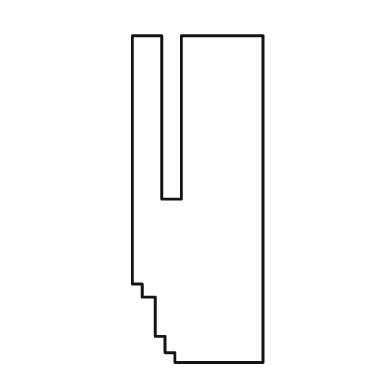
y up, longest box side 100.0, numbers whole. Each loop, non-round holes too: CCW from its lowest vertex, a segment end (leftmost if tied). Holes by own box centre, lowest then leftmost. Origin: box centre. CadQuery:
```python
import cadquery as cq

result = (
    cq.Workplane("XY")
    .moveTo(-7.0, -50.0)
    .lineTo(20.0, -50.0)
    .lineTo(20.0, 50.0)
    .lineTo(-5.0, 50.0)
    .lineTo(-5.0, 0.0)
    .lineTo(-11.0, 0.0)
    .lineTo(-11.0, 50.0)
    .lineTo(-20.0, 50.0)
    .lineTo(-20.0, -26.0)
    .lineTo(-17.0, -26.0)
    .lineTo(-17.0, -30.0)
    .lineTo(-13.0, -30.0)
    .lineTo(-13.0, -42.0)
    .lineTo(-10.0, -42.0)
    .lineTo(-10.0, -47.0)
    .lineTo(-7.0, -47.0)
    .close()
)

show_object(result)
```